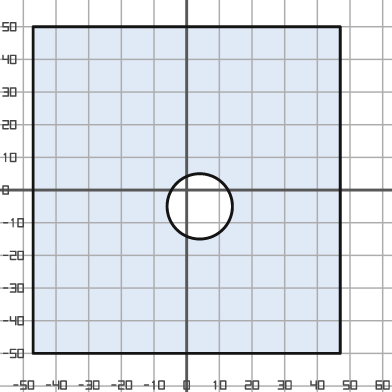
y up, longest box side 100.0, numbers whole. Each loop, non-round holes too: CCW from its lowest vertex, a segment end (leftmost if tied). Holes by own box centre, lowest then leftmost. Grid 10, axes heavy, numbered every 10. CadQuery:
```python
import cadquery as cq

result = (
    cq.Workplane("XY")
    .moveTo(-47.0, -50.0)
    .lineTo(47.0, -50.0)
    .lineTo(47.0, 50.0)
    .lineTo(-47.0, 50.0)
    .close()
    .moveTo(4.0, -5.0)
    .circle(10.0)
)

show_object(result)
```